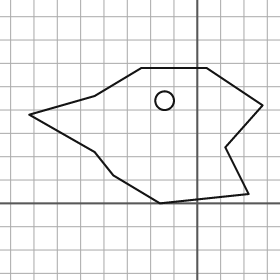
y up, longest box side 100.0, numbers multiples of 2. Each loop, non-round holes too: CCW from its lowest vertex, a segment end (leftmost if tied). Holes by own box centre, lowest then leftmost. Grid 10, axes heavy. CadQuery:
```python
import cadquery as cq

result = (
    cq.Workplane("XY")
    .moveTo(-16.0, 0.0)
    .lineTo(22.0, 4.0)
    .lineTo(12.0, 24.0)
    .lineTo(28.0, 42.0)
    .lineTo(4.0, 58.0)
    .lineTo(-24.0, 58.0)
    .lineTo(-44.0, 46.0)
    .lineTo(-72.0, 38.0)
    .lineTo(-44.0, 22.0)
    .lineTo(-36.0, 12.0)
    .close()
    .moveTo(-14.0, 44.0)
    .circle(4.0)
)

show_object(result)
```